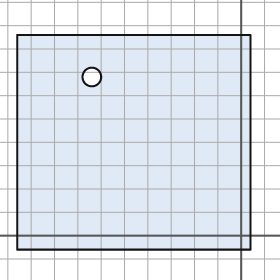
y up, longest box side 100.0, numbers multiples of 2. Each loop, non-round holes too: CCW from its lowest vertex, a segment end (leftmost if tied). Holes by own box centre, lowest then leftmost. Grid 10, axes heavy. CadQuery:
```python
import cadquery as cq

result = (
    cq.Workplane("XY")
    .moveTo(-96.0, -6.0)
    .lineTo(4.0, -6.0)
    .lineTo(4.0, 86.0)
    .lineTo(-96.0, 86.0)
    .close()
    .moveTo(-64.0, 68.0)
    .circle(4.0)
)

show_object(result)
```